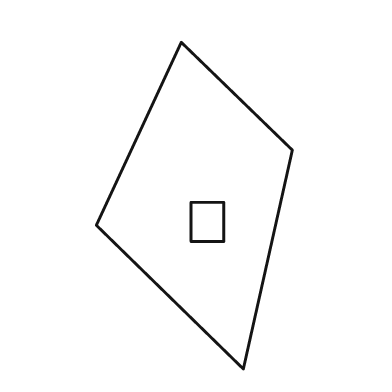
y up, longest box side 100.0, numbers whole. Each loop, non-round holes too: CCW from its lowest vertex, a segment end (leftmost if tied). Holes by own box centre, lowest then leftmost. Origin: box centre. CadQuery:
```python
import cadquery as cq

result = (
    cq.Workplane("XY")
    .moveTo(15.0, -50.0)
    .lineTo(30.0, 17.0)
    .lineTo(-4.0, 50.0)
    .lineTo(-30.0, -6.0)
    .close()
    .moveTo(-1.0, -11.0)
    .lineTo(9.0, -11.0)
    .lineTo(9.0, 1.0)
    .lineTo(-1.0, 1.0)
    .close()
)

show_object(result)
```